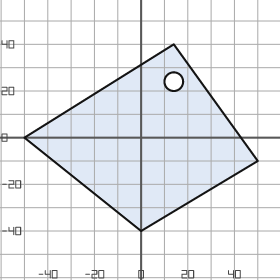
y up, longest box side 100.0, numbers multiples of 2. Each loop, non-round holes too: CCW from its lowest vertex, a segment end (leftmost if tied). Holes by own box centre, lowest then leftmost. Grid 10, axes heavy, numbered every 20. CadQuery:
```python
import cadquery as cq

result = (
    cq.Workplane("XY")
    .moveTo(0.0, -40.0)
    .lineTo(50.0, -10.0)
    .lineTo(14.0, 40.0)
    .lineTo(-50.0, 0.0)
    .close()
    .moveTo(14.0, 24.0)
    .circle(4.0)
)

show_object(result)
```